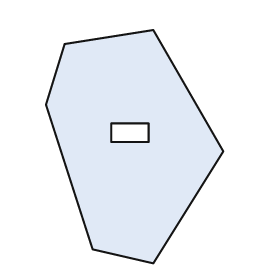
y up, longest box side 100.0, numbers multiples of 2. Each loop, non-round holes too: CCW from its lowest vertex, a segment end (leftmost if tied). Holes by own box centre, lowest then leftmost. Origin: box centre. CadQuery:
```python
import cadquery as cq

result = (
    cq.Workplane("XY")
    .moveTo(8.0, -50.0)
    .lineTo(38.0, -2.0)
    .lineTo(8.0, 50.0)
    .lineTo(-30.0, 44.0)
    .lineTo(-38.0, 18.0)
    .lineTo(-18.0, -44.0)
    .close()
    .moveTo(-10.0, 2.0)
    .lineTo(6.0, 2.0)
    .lineTo(6.0, 10.0)
    .lineTo(-10.0, 10.0)
    .close()
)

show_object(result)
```